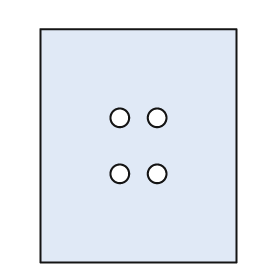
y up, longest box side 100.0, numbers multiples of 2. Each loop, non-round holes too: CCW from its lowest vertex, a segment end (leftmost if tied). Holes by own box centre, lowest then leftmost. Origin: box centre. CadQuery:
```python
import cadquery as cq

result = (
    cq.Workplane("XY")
    .moveTo(-42.0, -50.0)
    .lineTo(42.0, -50.0)
    .lineTo(42.0, 50.0)
    .lineTo(-42.0, 50.0)
    .close()
    .moveTo(-8.0, -12.0)
    .circle(4.0)
    .moveTo(8.0, -12.0)
    .circle(4.0)
    .moveTo(-8.0, 12.0)
    .circle(4.0)
    .moveTo(8.0, 12.0)
    .circle(4.0)
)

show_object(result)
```